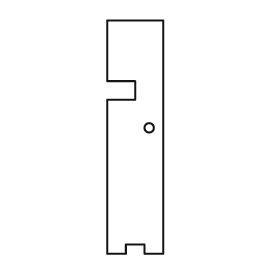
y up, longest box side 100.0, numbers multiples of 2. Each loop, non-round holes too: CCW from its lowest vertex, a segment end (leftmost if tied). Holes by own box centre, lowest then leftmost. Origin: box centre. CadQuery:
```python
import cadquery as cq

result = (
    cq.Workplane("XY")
    .moveTo(-12.0, -50.0)
    .lineTo(-4.0, -50.0)
    .lineTo(-4.0, -46.0)
    .lineTo(4.0, -46.0)
    .lineTo(4.0, -50.0)
    .lineTo(12.0, -50.0)
    .lineTo(12.0, 50.0)
    .lineTo(-12.0, 50.0)
    .lineTo(-12.0, 24.0)
    .lineTo(0.0, 24.0)
    .lineTo(0.0, 16.0)
    .lineTo(-12.0, 16.0)
    .close()
    .moveTo(6.0, 4.0)
    .circle(2.0)
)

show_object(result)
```